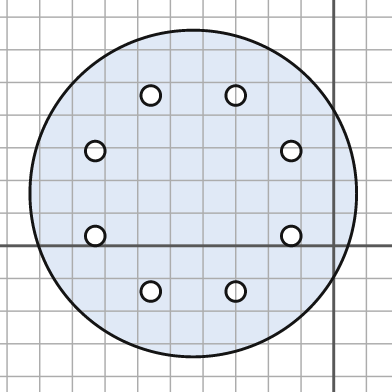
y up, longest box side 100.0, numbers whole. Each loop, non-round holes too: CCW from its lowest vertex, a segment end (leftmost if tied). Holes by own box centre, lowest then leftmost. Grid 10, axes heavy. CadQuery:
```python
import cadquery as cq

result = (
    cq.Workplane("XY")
    .moveTo(-43.0, 16.0)
    .circle(50.0)
    .moveTo(-56.0, -14.0)
    .circle(3.0)
    .moveTo(-30.0, -14.0)
    .circle(3.0)
    .moveTo(-73.0, 3.0)
    .circle(3.0)
    .moveTo(-13.0, 3.0)
    .circle(3.0)
    .moveTo(-73.0, 29.0)
    .circle(3.0)
    .moveTo(-13.0, 29.0)
    .circle(3.0)
    .moveTo(-56.0, 46.0)
    .circle(3.0)
    .moveTo(-30.0, 46.0)
    .circle(3.0)
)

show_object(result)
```